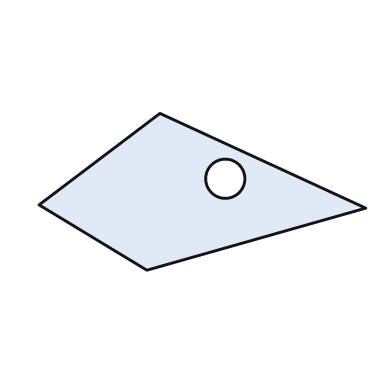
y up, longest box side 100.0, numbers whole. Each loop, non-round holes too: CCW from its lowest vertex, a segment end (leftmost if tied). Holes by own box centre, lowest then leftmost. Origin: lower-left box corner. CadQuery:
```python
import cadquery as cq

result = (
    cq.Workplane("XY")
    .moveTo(33.0, 0.0)
    .lineTo(100.0, 19.0)
    .lineTo(37.0, 48.0)
    .lineTo(0.0, 20.0)
    .close()
    .moveTo(57.0, 28.0)
    .circle(6.0)
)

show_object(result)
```